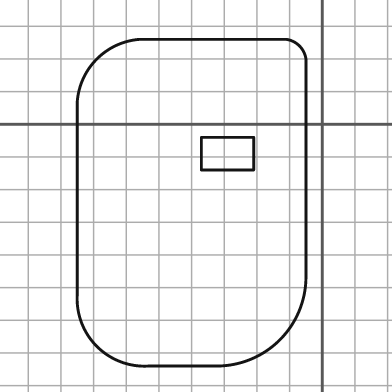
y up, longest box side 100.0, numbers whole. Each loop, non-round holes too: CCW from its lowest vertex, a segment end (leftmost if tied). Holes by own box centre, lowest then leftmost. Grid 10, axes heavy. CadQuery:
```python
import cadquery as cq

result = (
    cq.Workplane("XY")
    .moveTo(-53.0, -74.0)
    .lineTo(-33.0, -74.0)
    .threePointArc((-13.0, -66.0), (-5.0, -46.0))
    .lineTo(-5.0, 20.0)
    .threePointArc((-7.0, 24.0), (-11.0, 26.0))
    .lineTo(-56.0, 26.0)
    .threePointArc((-69.0, 20.0), (-75.0, 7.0))
    .lineTo(-75.0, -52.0)
    .threePointArc((-69.0, -68.0), (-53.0, -74.0))
    .close()
    .moveTo(-37.0, -14.0)
    .lineTo(-21.0, -14.0)
    .lineTo(-21.0, -4.0)
    .lineTo(-37.0, -4.0)
    .close()
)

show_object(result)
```